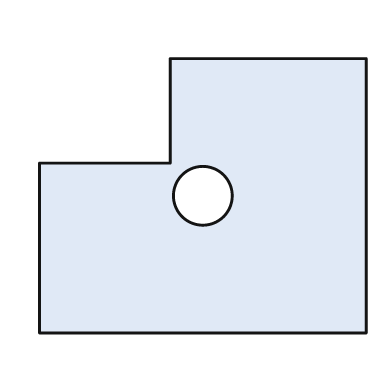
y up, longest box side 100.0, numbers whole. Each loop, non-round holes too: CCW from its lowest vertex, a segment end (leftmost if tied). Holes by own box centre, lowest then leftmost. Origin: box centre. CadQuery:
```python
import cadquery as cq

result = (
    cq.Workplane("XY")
    .moveTo(-50.0, -42.0)
    .lineTo(50.0, -42.0)
    .lineTo(50.0, 42.0)
    .lineTo(-10.0, 42.0)
    .lineTo(-10.0, 10.0)
    .lineTo(-50.0, 10.0)
    .close()
    .moveTo(0.0, 0.0)
    .circle(9.0)
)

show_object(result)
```